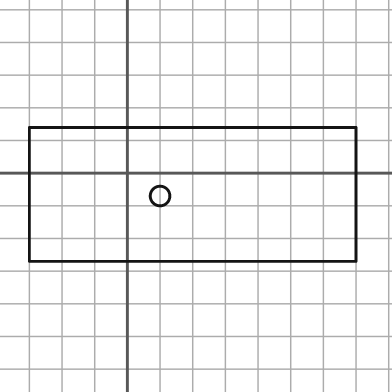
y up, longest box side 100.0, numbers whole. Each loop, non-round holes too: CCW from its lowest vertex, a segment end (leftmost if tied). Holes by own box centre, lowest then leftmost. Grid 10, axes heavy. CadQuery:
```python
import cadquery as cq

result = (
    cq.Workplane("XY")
    .moveTo(-30.0, -27.0)
    .lineTo(70.0, -27.0)
    .lineTo(70.0, 14.0)
    .lineTo(-30.0, 14.0)
    .close()
    .moveTo(10.0, -7.0)
    .circle(3.0)
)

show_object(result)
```